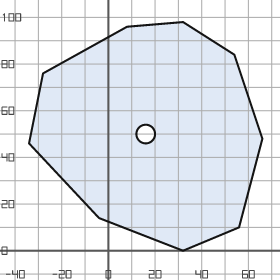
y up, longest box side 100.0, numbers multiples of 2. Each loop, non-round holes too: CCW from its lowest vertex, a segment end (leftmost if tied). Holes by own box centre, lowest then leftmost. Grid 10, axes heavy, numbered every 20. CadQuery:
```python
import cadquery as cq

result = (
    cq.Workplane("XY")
    .moveTo(32.0, 0.0)
    .lineTo(56.0, 10.0)
    .lineTo(66.0, 48.0)
    .lineTo(54.0, 84.0)
    .lineTo(32.0, 98.0)
    .lineTo(8.0, 96.0)
    .lineTo(-28.0, 76.0)
    .lineTo(-34.0, 46.0)
    .lineTo(-4.0, 14.0)
    .close()
    .moveTo(16.0, 50.0)
    .circle(4.0)
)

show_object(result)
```